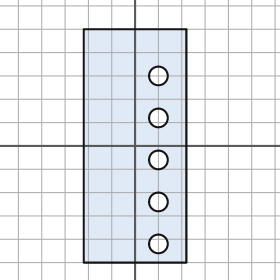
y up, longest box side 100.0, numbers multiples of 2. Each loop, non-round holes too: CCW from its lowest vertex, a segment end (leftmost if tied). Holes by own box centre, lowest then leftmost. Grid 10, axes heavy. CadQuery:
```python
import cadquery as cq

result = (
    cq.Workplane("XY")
    .moveTo(-22.0, -50.0)
    .lineTo(22.0, -50.0)
    .lineTo(22.0, 50.0)
    .lineTo(-22.0, 50.0)
    .close()
    .moveTo(10.0, -42.0)
    .circle(4.0)
    .moveTo(10.0, -24.0)
    .circle(4.0)
    .moveTo(10.0, -6.0)
    .circle(4.0)
    .moveTo(10.0, 12.0)
    .circle(4.0)
    .moveTo(10.0, 30.0)
    .circle(4.0)
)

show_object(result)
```